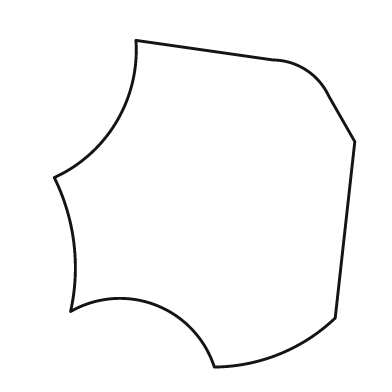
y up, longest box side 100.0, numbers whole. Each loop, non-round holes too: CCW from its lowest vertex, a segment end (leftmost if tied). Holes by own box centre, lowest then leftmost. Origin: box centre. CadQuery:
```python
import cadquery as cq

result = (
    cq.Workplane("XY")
    .moveTo(3.0, -50.0)
    .threePointArc((23.0, -46.0), (40.0, -35.0))
    .lineTo(46.0, 19.0)
    .lineTo(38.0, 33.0)
    .threePointArc((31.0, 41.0), (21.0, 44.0))
    .lineTo(-21.0, 50.0)
    .threePointArc((-27.0, 25.0), (-46.0, 8.0))
    .threePointArc((-40.0, -12.0), (-41.0, -33.0))
    .threePointArc((-15.0, -31.0), (3.0, -50.0))
    .close()
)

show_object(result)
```